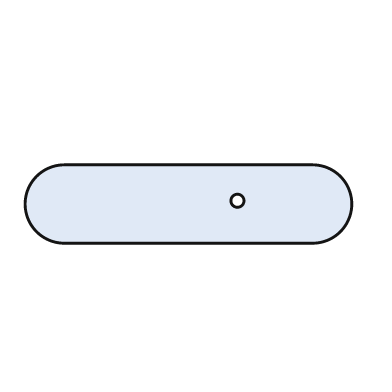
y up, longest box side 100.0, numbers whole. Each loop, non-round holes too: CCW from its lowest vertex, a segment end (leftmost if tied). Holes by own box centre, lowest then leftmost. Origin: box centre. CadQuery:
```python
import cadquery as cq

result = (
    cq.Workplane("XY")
    .moveTo(-38.0, -12.0)
    .lineTo(38.0, -12.0)
    .threePointArc((50.0, 0.0), (38.0, 12.0))
    .lineTo(-38.0, 12.0)
    .threePointArc((-50.0, 0.0), (-38.0, -12.0))
    .close()
    .moveTo(15.0, 1.0)
    .circle(2.0)
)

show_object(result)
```